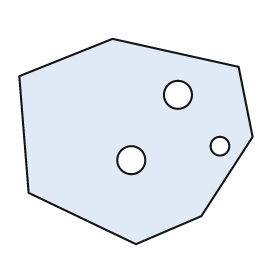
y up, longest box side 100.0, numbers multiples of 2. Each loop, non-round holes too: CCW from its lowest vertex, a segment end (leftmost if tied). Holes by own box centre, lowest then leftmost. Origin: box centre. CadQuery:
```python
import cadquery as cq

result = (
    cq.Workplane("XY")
    .moveTo(0.0, -44.0)
    .lineTo(28.0, -32.0)
    .lineTo(50.0, 2.0)
    .lineTo(44.0, 32.0)
    .lineTo(-10.0, 44.0)
    .lineTo(-50.0, 28.0)
    .lineTo(-46.0, -22.0)
    .close()
    .moveTo(-2.0, -8.0)
    .circle(6.0)
    .moveTo(36.0, -2.0)
    .circle(4.0)
    .moveTo(18.0, 20.0)
    .circle(6.0)
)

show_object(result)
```